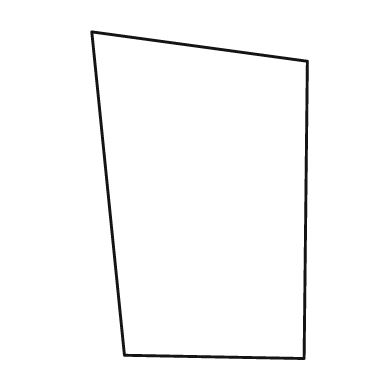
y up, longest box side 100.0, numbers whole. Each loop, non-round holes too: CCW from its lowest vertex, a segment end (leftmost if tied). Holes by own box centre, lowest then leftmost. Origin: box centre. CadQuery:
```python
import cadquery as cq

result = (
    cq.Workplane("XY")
    .moveTo(32.0, -50.0)
    .lineTo(33.0, 41.0)
    .lineTo(-33.0, 50.0)
    .lineTo(-23.0, -49.0)
    .close()
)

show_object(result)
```